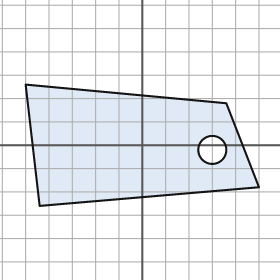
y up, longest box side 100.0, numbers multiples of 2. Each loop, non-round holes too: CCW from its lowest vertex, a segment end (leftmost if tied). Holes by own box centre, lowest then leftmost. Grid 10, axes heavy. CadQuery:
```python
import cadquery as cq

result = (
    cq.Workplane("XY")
    .moveTo(-44.0, -26.0)
    .lineTo(50.0, -18.0)
    .lineTo(36.0, 18.0)
    .lineTo(-50.0, 26.0)
    .close()
    .moveTo(30.0, -2.0)
    .circle(6.0)
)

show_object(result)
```